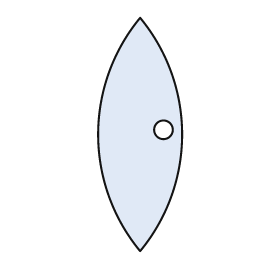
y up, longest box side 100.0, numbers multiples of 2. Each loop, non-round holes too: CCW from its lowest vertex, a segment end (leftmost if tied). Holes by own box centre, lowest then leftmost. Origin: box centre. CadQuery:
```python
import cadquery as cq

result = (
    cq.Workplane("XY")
    .moveTo(0.0, -50.0)
    .threePointArc((18.0, 0.0), (0.0, 50.0))
    .threePointArc((-18.0, 0.0), (0.0, -50.0))
    .close()
    .moveTo(10.0, 2.0)
    .circle(4.0)
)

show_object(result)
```